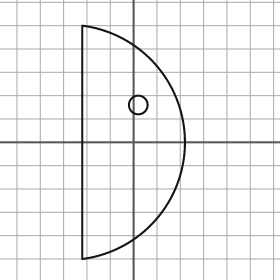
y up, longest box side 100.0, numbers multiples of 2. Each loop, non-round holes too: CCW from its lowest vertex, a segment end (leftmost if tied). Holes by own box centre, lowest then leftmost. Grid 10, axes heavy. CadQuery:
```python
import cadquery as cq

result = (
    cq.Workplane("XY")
    .moveTo(-22.0, -50.0)
    .threePointArc((22.0, 0.0), (-22.0, 50.0))
    .close()
    .moveTo(2.0, 16.0)
    .circle(4.0)
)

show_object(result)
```